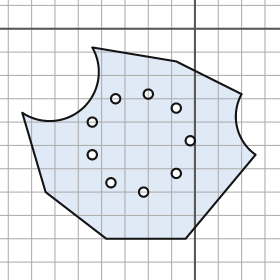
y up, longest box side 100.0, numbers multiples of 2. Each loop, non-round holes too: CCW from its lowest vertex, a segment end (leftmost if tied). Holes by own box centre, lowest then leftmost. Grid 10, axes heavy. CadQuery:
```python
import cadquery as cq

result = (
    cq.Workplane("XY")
    .moveTo(-38.0, -90.0)
    .lineTo(-4.0, -90.0)
    .lineTo(26.0, -54.0)
    .threePointArc((18.0, -42.0), (20.0, -28.0))
    .lineTo(-8.0, -14.0)
    .lineTo(-44.0, -8.0)
    .threePointArc((-48.0, -34.0), (-74.0, -36.0))
    .lineTo(-64.0, -70.0)
    .close()
    .moveTo(-22.0, -70.0)
    .circle(2.0)
    .moveTo(-36.0, -66.0)
    .circle(2.0)
    .moveTo(-8.0, -62.0)
    .circle(2.0)
    .moveTo(-44.0, -54.0)
    .circle(2.0)
    .moveTo(-2.0, -48.0)
    .circle(2.0)
    .moveTo(-44.0, -40.0)
    .circle(2.0)
    .moveTo(-8.0, -34.0)
    .circle(2.0)
    .moveTo(-34.0, -30.0)
    .circle(2.0)
    .moveTo(-20.0, -28.0)
    .circle(2.0)
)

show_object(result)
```